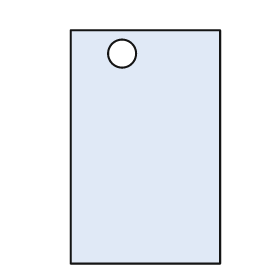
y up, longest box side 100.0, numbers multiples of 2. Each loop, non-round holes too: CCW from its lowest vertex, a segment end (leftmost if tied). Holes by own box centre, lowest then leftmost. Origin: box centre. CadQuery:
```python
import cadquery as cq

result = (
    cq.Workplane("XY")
    .moveTo(-32.0, -50.0)
    .lineTo(32.0, -50.0)
    .lineTo(32.0, 50.0)
    .lineTo(-32.0, 50.0)
    .close()
    .moveTo(-10.0, 40.0)
    .circle(6.0)
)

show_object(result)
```